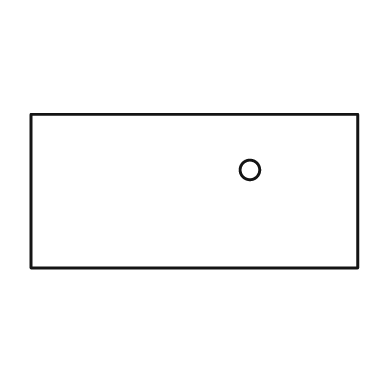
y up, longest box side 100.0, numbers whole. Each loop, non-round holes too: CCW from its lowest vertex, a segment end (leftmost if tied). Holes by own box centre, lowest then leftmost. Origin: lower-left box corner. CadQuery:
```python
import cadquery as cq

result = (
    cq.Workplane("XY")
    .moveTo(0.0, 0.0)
    .lineTo(100.0, 0.0)
    .lineTo(100.0, 47.0)
    .lineTo(0.0, 47.0)
    .close()
    .moveTo(67.0, 30.0)
    .circle(3.0)
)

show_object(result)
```